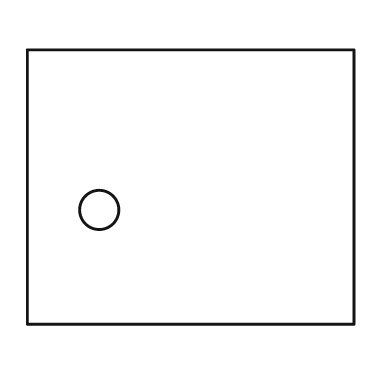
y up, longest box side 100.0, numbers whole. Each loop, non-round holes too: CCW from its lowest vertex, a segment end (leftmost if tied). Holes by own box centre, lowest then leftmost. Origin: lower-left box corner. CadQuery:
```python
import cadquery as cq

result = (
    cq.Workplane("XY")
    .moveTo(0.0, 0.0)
    .lineTo(100.0, 0.0)
    .lineTo(100.0, 84.0)
    .lineTo(0.0, 84.0)
    .close()
    .moveTo(22.0, 35.0)
    .circle(6.0)
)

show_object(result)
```